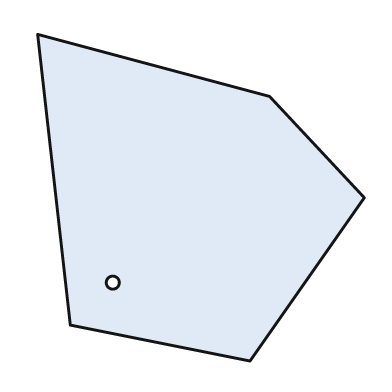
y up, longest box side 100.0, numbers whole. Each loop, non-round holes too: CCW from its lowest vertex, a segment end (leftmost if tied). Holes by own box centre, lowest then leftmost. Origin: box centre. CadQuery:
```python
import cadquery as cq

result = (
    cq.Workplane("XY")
    .moveTo(15.0, -50.0)
    .lineTo(50.0, 0.0)
    .lineTo(21.0, 31.0)
    .lineTo(-50.0, 50.0)
    .lineTo(-40.0, -39.0)
    .close()
    .moveTo(-27.0, -26.0)
    .circle(2.0)
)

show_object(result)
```